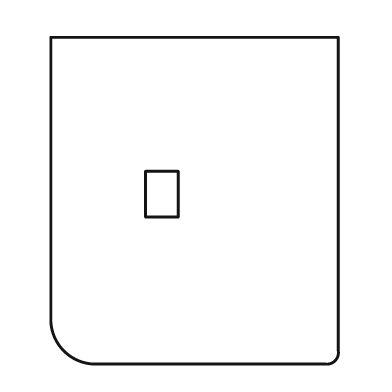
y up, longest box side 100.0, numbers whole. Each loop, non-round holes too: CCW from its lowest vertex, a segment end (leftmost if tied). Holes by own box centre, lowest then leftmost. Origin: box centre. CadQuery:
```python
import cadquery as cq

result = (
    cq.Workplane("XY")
    .moveTo(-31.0, -50.0)
    .lineTo(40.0, -50.0)
    .threePointArc((43.0, -49.0), (44.0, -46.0))
    .lineTo(44.0, 50.0)
    .lineTo(-44.0, 50.0)
    .lineTo(-44.0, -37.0)
    .threePointArc((-40.0, -46.0), (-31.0, -50.0))
    .close()
    .moveTo(-15.0, -5.0)
    .lineTo(-5.0, -5.0)
    .lineTo(-5.0, 9.0)
    .lineTo(-15.0, 9.0)
    .close()
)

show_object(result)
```